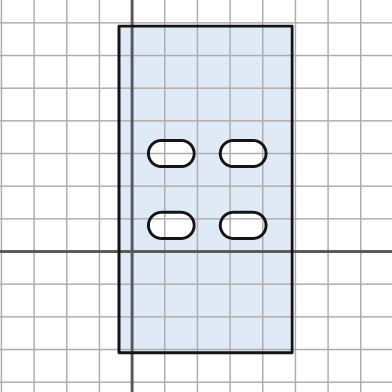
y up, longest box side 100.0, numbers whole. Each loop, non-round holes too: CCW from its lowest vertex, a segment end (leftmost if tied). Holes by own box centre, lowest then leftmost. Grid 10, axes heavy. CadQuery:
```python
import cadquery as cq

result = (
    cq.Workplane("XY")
    .moveTo(-4.0, -31.0)
    .lineTo(49.0, -31.0)
    .lineTo(49.0, 69.0)
    .lineTo(-4.0, 69.0)
    .close()
    .moveTo(9.0, 4.0)
    .lineTo(15.0, 4.0)
    .threePointArc((19.0, 8.0), (15.0, 12.0))
    .lineTo(9.0, 12.0)
    .threePointArc((5.0, 8.0), (9.0, 4.0))
    .close()
    .moveTo(31.0, 4.0)
    .lineTo(37.0, 4.0)
    .threePointArc((41.0, 8.0), (37.0, 12.0))
    .lineTo(31.0, 12.0)
    .threePointArc((27.0, 8.0), (31.0, 4.0))
    .close()
    .moveTo(9.0, 26.0)
    .lineTo(15.0, 26.0)
    .threePointArc((19.0, 30.0), (15.0, 34.0))
    .lineTo(9.0, 34.0)
    .threePointArc((5.0, 30.0), (9.0, 26.0))
    .close()
    .moveTo(31.0, 26.0)
    .lineTo(37.0, 26.0)
    .threePointArc((41.0, 30.0), (37.0, 34.0))
    .lineTo(31.0, 34.0)
    .threePointArc((27.0, 30.0), (31.0, 26.0))
    .close()
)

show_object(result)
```